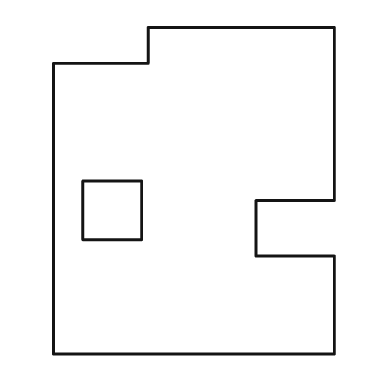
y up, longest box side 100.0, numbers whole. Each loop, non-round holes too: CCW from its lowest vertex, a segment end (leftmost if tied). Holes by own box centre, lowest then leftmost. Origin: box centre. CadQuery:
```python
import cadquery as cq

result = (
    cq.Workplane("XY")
    .moveTo(-43.0, -50.0)
    .lineTo(43.0, -50.0)
    .lineTo(43.0, -20.0)
    .lineTo(19.0, -20.0)
    .lineTo(19.0, -3.0)
    .lineTo(43.0, -3.0)
    .lineTo(43.0, 50.0)
    .lineTo(-14.0, 50.0)
    .lineTo(-14.0, 39.0)
    .lineTo(-43.0, 39.0)
    .close()
    .moveTo(-34.0, -15.0)
    .lineTo(-16.0, -15.0)
    .lineTo(-16.0, 3.0)
    .lineTo(-34.0, 3.0)
    .close()
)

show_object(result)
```